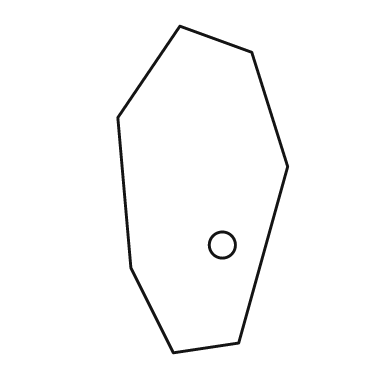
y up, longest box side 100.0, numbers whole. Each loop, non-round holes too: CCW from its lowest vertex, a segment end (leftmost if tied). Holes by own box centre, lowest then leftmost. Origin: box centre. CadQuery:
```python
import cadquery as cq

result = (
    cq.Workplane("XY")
    .moveTo(-9.0, -50.0)
    .lineTo(11.0, -47.0)
    .lineTo(26.0, 7.0)
    .lineTo(15.0, 42.0)
    .lineTo(-7.0, 50.0)
    .lineTo(-26.0, 22.0)
    .lineTo(-22.0, -24.0)
    .close()
    .moveTo(6.0, -17.0)
    .circle(4.0)
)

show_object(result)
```